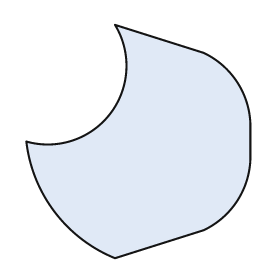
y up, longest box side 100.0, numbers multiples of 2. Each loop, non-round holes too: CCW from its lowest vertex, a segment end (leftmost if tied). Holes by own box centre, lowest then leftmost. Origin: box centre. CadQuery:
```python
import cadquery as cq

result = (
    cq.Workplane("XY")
    .moveTo(-10.0, -50.0)
    .lineTo(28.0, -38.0)
    .threePointArc((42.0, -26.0), (48.0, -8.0))
    .lineTo(48.0, 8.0)
    .threePointArc((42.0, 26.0), (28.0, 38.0))
    .lineTo(-10.0, 50.0)
    .threePointArc((-12.0, 12.0), (-48.0, 0.0))
    .threePointArc((-36.0, -30.0), (-10.0, -50.0))
    .close()
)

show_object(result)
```